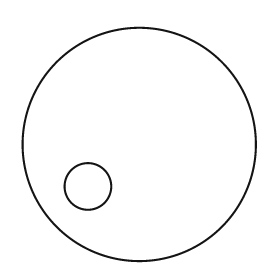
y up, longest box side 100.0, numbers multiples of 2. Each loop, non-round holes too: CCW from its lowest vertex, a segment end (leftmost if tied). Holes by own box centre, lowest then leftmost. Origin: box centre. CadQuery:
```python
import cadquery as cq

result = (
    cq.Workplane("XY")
    .moveTo(0.0, 0.0)
    .circle(50.0)
    .moveTo(-22.0, -18.0)
    .circle(10.0)
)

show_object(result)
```